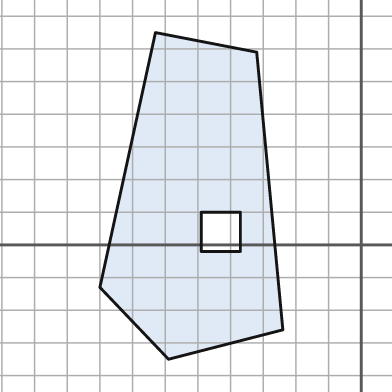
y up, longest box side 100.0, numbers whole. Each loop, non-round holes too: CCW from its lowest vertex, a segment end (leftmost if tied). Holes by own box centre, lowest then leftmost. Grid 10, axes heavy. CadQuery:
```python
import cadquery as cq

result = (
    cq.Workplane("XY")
    .moveTo(-59.0, -35.0)
    .lineTo(-24.0, -26.0)
    .lineTo(-32.0, 59.0)
    .lineTo(-63.0, 65.0)
    .lineTo(-80.0, -13.0)
    .close()
    .moveTo(-49.0, -2.0)
    .lineTo(-37.0, -2.0)
    .lineTo(-37.0, 10.0)
    .lineTo(-49.0, 10.0)
    .close()
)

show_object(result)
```